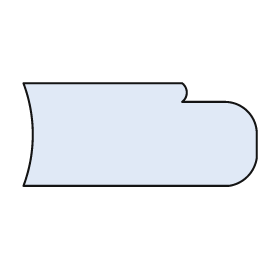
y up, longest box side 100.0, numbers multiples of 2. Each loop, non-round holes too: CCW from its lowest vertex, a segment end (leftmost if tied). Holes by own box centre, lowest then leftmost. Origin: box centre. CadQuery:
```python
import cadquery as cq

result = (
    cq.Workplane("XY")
    .moveTo(-50.0, -22.0)
    .lineTo(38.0, -22.0)
    .threePointArc((46.0, -18.0), (50.0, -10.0))
    .lineTo(50.0, 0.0)
    .threePointArc((46.0, 10.0), (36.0, 14.0))
    .lineTo(18.0, 14.0)
    .threePointArc((20.0, 18.0), (18.0, 22.0))
    .lineTo(-50.0, 22.0)
    .threePointArc((-46.0, 0.0), (-50.0, -22.0))
    .close()
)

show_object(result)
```